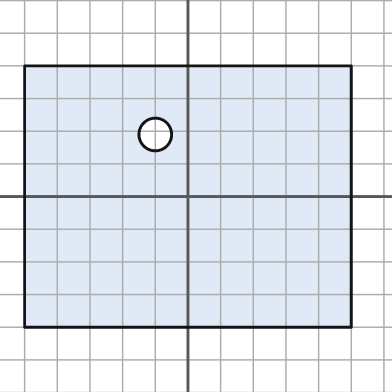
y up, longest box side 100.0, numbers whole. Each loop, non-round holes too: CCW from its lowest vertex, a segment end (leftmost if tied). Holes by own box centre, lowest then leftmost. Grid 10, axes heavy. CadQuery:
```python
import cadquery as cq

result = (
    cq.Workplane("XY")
    .moveTo(-50.0, -40.0)
    .lineTo(50.0, -40.0)
    .lineTo(50.0, 40.0)
    .lineTo(-50.0, 40.0)
    .close()
    .moveTo(-10.0, 19.0)
    .circle(5.0)
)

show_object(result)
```